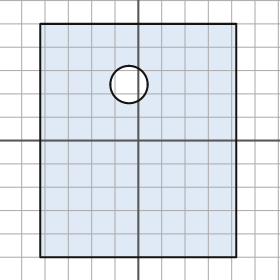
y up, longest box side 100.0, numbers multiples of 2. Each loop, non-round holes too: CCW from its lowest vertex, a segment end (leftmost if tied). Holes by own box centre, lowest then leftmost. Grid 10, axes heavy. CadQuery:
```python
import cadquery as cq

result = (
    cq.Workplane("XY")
    .moveTo(-42.0, -50.0)
    .lineTo(42.0, -50.0)
    .lineTo(42.0, 50.0)
    .lineTo(-42.0, 50.0)
    .close()
    .moveTo(-4.0, 24.0)
    .circle(8.0)
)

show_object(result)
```